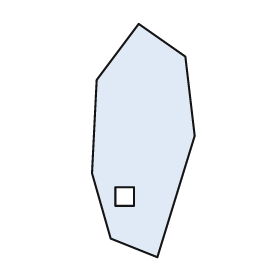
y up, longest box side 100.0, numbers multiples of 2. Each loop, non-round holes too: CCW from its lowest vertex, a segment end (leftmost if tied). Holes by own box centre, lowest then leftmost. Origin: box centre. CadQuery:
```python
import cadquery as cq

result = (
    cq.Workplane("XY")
    .moveTo(6.0, -50.0)
    .lineTo(22.0, 2.0)
    .lineTo(18.0, 36.0)
    .lineTo(-2.0, 50.0)
    .lineTo(-20.0, 26.0)
    .lineTo(-22.0, -14.0)
    .lineTo(-14.0, -42.0)
    .close()
    .moveTo(-12.0, -28.0)
    .lineTo(-4.0, -28.0)
    .lineTo(-4.0, -20.0)
    .lineTo(-12.0, -20.0)
    .close()
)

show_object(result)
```